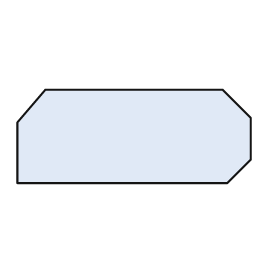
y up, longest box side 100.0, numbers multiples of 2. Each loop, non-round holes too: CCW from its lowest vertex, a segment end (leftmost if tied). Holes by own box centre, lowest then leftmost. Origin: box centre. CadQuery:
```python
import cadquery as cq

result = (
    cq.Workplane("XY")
    .moveTo(-50.0, -20.0)
    .lineTo(40.0, -20.0)
    .lineTo(50.0, -10.0)
    .lineTo(50.0, 8.0)
    .lineTo(38.0, 20.0)
    .lineTo(-38.0, 20.0)
    .lineTo(-50.0, 6.0)
    .close()
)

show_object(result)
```